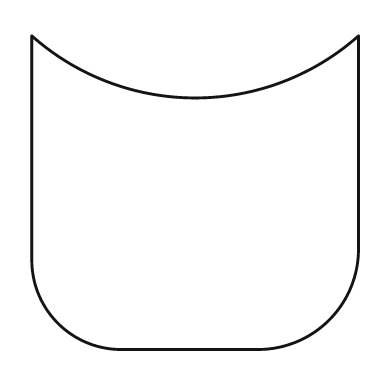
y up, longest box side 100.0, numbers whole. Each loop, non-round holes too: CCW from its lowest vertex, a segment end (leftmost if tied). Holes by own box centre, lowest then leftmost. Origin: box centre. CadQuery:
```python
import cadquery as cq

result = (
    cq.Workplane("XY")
    .moveTo(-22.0, -48.0)
    .lineTo(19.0, -48.0)
    .threePointArc((41.0, -39.0), (50.0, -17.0))
    .lineTo(50.0, 48.0)
    .threePointArc((0.0, 29.0), (-50.0, 48.0))
    .lineTo(-50.0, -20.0)
    .threePointArc((-42.0, -40.0), (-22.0, -48.0))
    .close()
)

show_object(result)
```